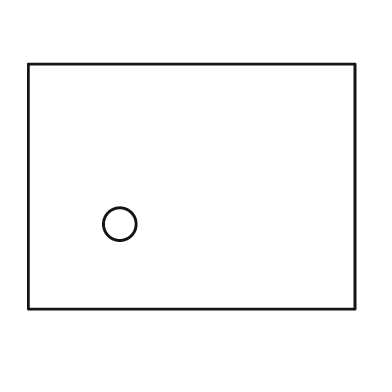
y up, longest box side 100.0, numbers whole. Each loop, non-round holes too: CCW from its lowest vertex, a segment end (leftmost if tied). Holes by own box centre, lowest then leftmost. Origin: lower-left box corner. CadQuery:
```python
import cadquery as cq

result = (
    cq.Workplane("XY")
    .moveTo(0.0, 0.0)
    .lineTo(100.0, 0.0)
    .lineTo(100.0, 75.0)
    .lineTo(0.0, 75.0)
    .close()
    .moveTo(28.0, 26.0)
    .circle(5.0)
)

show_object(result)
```